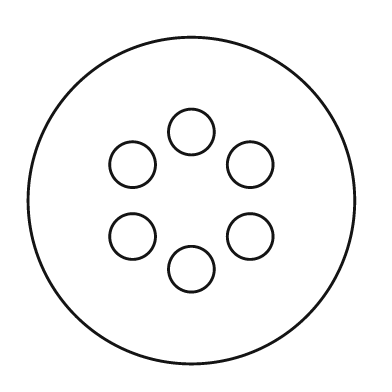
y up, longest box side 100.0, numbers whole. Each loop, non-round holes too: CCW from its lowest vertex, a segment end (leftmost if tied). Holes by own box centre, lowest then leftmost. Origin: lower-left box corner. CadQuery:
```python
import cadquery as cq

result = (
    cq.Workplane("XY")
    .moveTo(50.0, 50.0)
    .circle(50.0)
    .moveTo(50.0, 29.0)
    .circle(7.0)
    .moveTo(32.0, 39.0)
    .circle(7.0)
    .moveTo(68.0, 39.0)
    .circle(7.0)
    .moveTo(32.0, 61.0)
    .circle(7.0)
    .moveTo(68.0, 61.0)
    .circle(7.0)
    .moveTo(50.0, 71.0)
    .circle(7.0)
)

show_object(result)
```